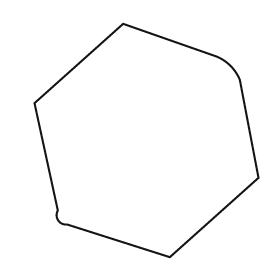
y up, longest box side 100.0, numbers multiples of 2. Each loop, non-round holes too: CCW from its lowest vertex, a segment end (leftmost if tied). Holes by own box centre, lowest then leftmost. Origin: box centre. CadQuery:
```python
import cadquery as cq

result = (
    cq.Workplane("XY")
    .moveTo(10.0, -50.0)
    .lineTo(48.0, -16.0)
    .lineTo(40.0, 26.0)
    .threePointArc((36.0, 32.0), (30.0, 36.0))
    .lineTo(-10.0, 50.0)
    .lineTo(-48.0, 16.0)
    .lineTo(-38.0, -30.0)
    .threePointArc((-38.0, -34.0), (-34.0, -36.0))
    .close()
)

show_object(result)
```